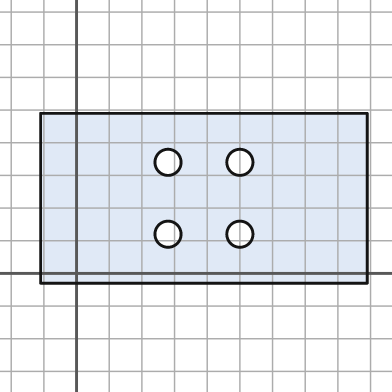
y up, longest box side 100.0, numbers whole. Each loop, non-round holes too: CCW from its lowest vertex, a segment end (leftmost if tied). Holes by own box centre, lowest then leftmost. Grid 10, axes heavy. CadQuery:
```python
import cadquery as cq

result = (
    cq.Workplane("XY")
    .moveTo(-11.0, -3.0)
    .lineTo(89.0, -3.0)
    .lineTo(89.0, 49.0)
    .lineTo(-11.0, 49.0)
    .close()
    .moveTo(28.0, 12.0)
    .circle(4.0)
    .moveTo(50.0, 12.0)
    .circle(4.0)
    .moveTo(28.0, 34.0)
    .circle(4.0)
    .moveTo(50.0, 34.0)
    .circle(4.0)
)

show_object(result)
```